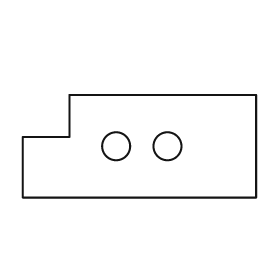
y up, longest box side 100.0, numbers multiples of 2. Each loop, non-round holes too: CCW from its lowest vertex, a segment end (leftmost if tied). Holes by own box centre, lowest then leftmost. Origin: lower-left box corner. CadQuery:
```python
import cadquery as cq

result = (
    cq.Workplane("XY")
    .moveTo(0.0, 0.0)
    .lineTo(100.0, 0.0)
    .lineTo(100.0, 44.0)
    .lineTo(20.0, 44.0)
    .lineTo(20.0, 26.0)
    .lineTo(0.0, 26.0)
    .close()
    .moveTo(40.0, 22.0)
    .circle(6.0)
    .moveTo(62.0, 22.0)
    .circle(6.0)
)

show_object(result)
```